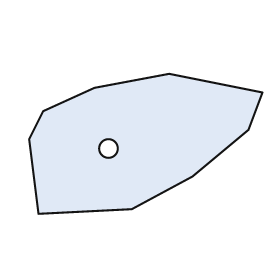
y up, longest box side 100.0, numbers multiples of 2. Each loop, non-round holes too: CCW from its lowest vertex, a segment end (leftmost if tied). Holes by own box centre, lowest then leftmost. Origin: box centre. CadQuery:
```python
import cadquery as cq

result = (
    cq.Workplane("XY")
    .moveTo(-46.0, -30.0)
    .lineTo(-6.0, -28.0)
    .lineTo(20.0, -14.0)
    .lineTo(44.0, 6.0)
    .lineTo(50.0, 22.0)
    .lineTo(10.0, 30.0)
    .lineTo(-22.0, 24.0)
    .lineTo(-44.0, 14.0)
    .lineTo(-50.0, 2.0)
    .close()
    .moveTo(-16.0, -2.0)
    .circle(4.0)
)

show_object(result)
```